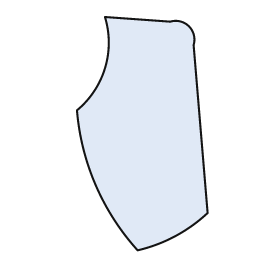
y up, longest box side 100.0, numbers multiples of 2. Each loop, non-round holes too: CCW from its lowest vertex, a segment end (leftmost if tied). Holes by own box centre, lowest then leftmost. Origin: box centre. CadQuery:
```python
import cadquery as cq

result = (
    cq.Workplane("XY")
    .moveTo(-2.0, -50.0)
    .threePointArc((14.0, -44.0), (28.0, -34.0))
    .lineTo(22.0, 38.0)
    .threePointArc((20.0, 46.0), (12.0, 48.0))
    .lineTo(-16.0, 50.0)
    .threePointArc((-16.0, 28.0), (-28.0, 10.0))
    .threePointArc((-20.0, -22.0), (-2.0, -50.0))
    .close()
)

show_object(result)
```